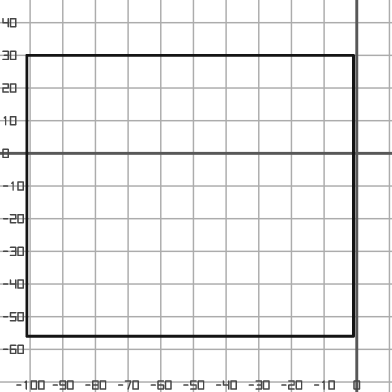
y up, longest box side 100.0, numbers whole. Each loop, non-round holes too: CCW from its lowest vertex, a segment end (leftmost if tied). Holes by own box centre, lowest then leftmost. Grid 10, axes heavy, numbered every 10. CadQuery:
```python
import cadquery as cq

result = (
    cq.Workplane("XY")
    .moveTo(-101.0, -56.0)
    .lineTo(-1.0, -56.0)
    .lineTo(-1.0, 30.0)
    .lineTo(-101.0, 30.0)
    .close()
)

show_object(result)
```